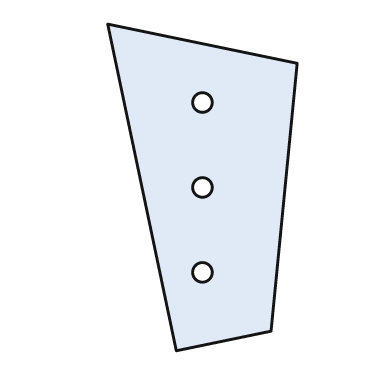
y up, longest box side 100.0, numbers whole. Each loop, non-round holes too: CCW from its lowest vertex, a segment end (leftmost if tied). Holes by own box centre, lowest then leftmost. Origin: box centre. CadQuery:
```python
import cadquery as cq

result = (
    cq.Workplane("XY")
    .moveTo(-8.0, -50.0)
    .lineTo(21.0, -44.0)
    .lineTo(29.0, 38.0)
    .lineTo(-29.0, 50.0)
    .close()
    .moveTo(0.0, -26.0)
    .circle(3.0)
    .moveTo(0.0, 0.0)
    .circle(3.0)
    .moveTo(0.0, 26.0)
    .circle(3.0)
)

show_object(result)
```